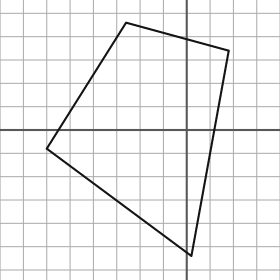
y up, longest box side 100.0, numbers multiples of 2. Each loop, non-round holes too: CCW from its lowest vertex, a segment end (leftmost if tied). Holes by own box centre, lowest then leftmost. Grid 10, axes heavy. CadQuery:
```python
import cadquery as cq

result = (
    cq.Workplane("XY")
    .moveTo(2.0, -54.0)
    .lineTo(18.0, 34.0)
    .lineTo(-26.0, 46.0)
    .lineTo(-60.0, -8.0)
    .close()
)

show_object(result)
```